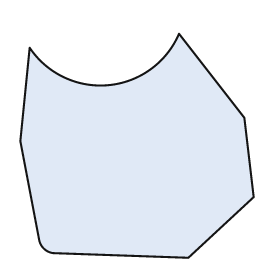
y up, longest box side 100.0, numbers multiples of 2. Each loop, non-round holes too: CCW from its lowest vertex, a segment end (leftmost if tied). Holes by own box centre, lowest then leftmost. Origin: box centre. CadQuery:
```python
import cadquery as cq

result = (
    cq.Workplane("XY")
    .moveTo(22.0, -48.0)
    .lineTo(50.0, -22.0)
    .lineTo(46.0, 12.0)
    .lineTo(18.0, 48.0)
    .threePointArc((-12.0, 26.0), (-46.0, 42.0))
    .lineTo(-50.0, 2.0)
    .lineTo(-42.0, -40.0)
    .threePointArc((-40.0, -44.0), (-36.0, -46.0))
    .close()
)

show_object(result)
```